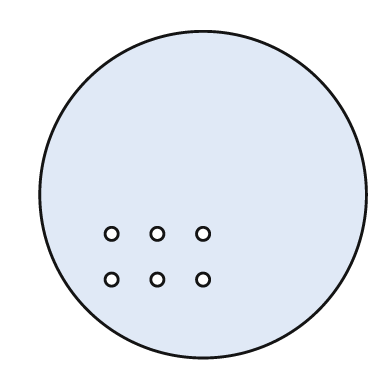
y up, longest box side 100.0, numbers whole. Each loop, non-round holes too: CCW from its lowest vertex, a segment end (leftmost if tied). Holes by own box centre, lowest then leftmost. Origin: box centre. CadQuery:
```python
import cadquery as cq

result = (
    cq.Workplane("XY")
    .moveTo(0.0, 0.0)
    .circle(50.0)
    .moveTo(-28.0, -26.0)
    .circle(2.0)
    .moveTo(-14.0, -26.0)
    .circle(2.0)
    .moveTo(0.0, -26.0)
    .circle(2.0)
    .moveTo(-28.0, -12.0)
    .circle(2.0)
    .moveTo(-14.0, -12.0)
    .circle(2.0)
    .moveTo(0.0, -12.0)
    .circle(2.0)
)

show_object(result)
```